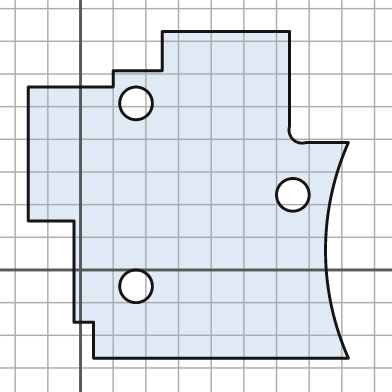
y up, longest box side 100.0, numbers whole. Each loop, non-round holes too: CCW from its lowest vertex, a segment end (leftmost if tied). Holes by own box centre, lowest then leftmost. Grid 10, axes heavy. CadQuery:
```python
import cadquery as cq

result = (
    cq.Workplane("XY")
    .moveTo(4.0, -27.0)
    .lineTo(82.0, -27.0)
    .threePointArc((75.0, 6.0), (82.0, 39.0))
    .lineTo(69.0, 39.0)
    .threePointArc((65.0, 40.0), (64.0, 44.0))
    .lineTo(64.0, 73.0)
    .lineTo(25.0, 73.0)
    .lineTo(25.0, 61.0)
    .lineTo(10.0, 61.0)
    .lineTo(10.0, 56.0)
    .lineTo(-16.0, 56.0)
    .lineTo(-16.0, 15.0)
    .lineTo(-2.0, 15.0)
    .lineTo(-2.0, -16.0)
    .lineTo(4.0, -16.0)
    .close()
    .moveTo(17.0, -5.0)
    .circle(5.0)
    .moveTo(65.0, 23.0)
    .circle(5.0)
    .moveTo(17.0, 51.0)
    .circle(5.0)
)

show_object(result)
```